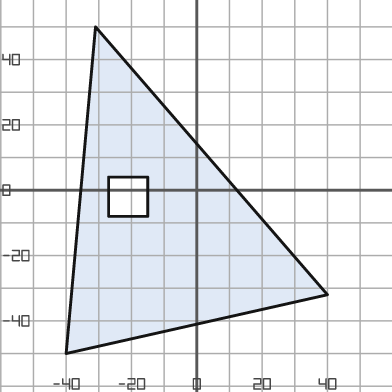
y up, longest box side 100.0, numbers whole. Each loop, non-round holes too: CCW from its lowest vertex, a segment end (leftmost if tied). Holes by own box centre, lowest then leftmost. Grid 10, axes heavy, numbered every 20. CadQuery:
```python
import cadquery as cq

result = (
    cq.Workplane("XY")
    .moveTo(-40.0, -50.0)
    .lineTo(40.0, -32.0)
    .lineTo(-31.0, 50.0)
    .close()
    .moveTo(-27.0, -8.0)
    .lineTo(-15.0, -8.0)
    .lineTo(-15.0, 4.0)
    .lineTo(-27.0, 4.0)
    .close()
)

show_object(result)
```